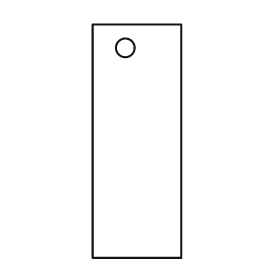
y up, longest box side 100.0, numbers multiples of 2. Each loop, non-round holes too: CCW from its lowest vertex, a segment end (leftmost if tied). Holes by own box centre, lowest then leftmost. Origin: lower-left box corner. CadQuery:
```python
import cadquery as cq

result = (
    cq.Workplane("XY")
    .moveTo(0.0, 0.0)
    .lineTo(38.0, 0.0)
    .lineTo(38.0, 100.0)
    .lineTo(0.0, 100.0)
    .close()
    .moveTo(14.0, 90.0)
    .circle(4.0)
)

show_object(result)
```